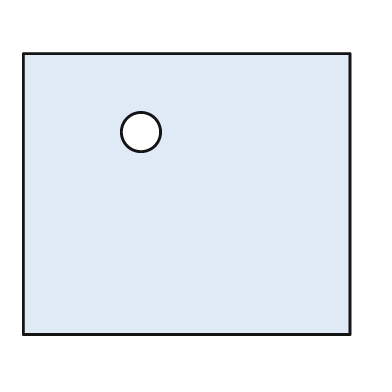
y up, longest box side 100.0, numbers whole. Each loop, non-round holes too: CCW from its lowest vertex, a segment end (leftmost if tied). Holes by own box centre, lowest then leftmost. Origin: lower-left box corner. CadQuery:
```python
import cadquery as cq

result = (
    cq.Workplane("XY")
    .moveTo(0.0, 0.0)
    .lineTo(100.0, 0.0)
    .lineTo(100.0, 86.0)
    .lineTo(0.0, 86.0)
    .close()
    .moveTo(36.0, 62.0)
    .circle(6.0)
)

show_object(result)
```